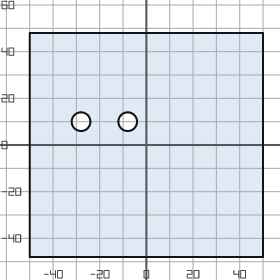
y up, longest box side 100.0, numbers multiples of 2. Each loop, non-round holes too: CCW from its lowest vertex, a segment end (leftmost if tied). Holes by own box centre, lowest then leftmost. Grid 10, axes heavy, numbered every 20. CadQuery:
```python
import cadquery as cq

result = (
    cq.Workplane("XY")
    .moveTo(-50.0, -48.0)
    .lineTo(50.0, -48.0)
    .lineTo(50.0, 48.0)
    .lineTo(-50.0, 48.0)
    .close()
    .moveTo(-28.0, 10.0)
    .circle(4.0)
    .moveTo(-8.0, 10.0)
    .circle(4.0)
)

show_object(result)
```